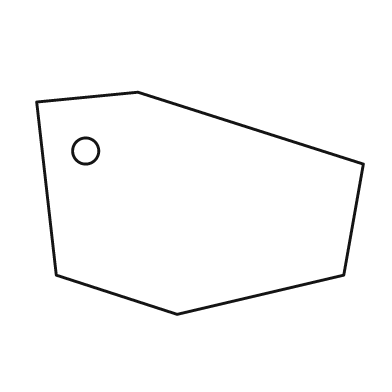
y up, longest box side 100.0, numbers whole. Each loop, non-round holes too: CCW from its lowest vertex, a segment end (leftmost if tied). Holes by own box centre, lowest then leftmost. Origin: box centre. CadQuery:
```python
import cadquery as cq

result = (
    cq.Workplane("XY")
    .moveTo(-7.0, -34.0)
    .lineTo(44.0, -22.0)
    .lineTo(50.0, 12.0)
    .lineTo(-19.0, 34.0)
    .lineTo(-50.0, 31.0)
    .lineTo(-44.0, -22.0)
    .close()
    .moveTo(-35.0, 16.0)
    .circle(4.0)
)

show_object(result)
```